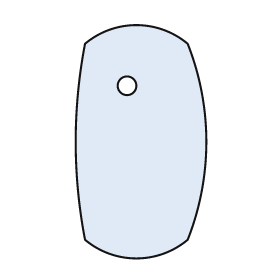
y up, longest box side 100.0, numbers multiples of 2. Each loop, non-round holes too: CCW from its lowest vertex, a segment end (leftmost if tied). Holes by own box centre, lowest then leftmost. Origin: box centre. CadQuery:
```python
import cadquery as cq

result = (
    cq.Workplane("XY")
    .moveTo(-24.0, -42.0)
    .threePointArc((-2.0, -50.0), (20.0, -42.0))
    .threePointArc((28.0, 0.0), (20.0, 42.0))
    .threePointArc((-2.0, 50.0), (-24.0, 42.0))
    .threePointArc((-28.0, 0.0), (-24.0, -42.0))
    .close()
    .moveTo(-6.0, 24.0)
    .circle(4.0)
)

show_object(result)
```